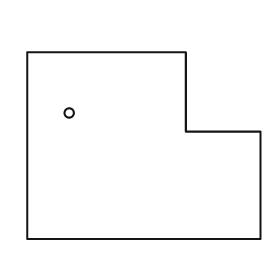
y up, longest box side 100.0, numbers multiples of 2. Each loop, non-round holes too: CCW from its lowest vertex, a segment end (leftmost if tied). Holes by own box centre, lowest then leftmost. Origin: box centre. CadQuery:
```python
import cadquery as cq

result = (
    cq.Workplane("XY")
    .moveTo(-50.0, -40.0)
    .lineTo(50.0, -40.0)
    .lineTo(50.0, 6.0)
    .lineTo(18.0, 6.0)
    .lineTo(18.0, 40.0)
    .lineTo(-50.0, 40.0)
    .close()
    .moveTo(-32.0, 14.0)
    .circle(2.0)
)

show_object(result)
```